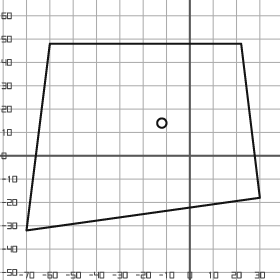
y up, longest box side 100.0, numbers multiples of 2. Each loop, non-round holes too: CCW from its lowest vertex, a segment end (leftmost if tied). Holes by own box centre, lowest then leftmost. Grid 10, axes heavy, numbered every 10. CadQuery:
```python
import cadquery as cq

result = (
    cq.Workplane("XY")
    .moveTo(-70.0, -32.0)
    .lineTo(30.0, -18.0)
    .lineTo(22.0, 48.0)
    .lineTo(-60.0, 48.0)
    .close()
    .moveTo(-12.0, 14.0)
    .circle(2.0)
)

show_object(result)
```